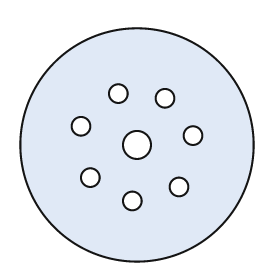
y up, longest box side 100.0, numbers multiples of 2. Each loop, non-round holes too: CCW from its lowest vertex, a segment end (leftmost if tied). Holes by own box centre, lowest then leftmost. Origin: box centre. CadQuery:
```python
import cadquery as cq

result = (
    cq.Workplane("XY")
    .moveTo(0.0, 0.0)
    .circle(50.0)
    .moveTo(-2.0, -24.0)
    .circle(4.0)
    .moveTo(18.0, -18.0)
    .circle(4.0)
    .moveTo(-20.0, -14.0)
    .circle(4.0)
    .moveTo(0.0, 0.0)
    .circle(6.0)
    .moveTo(24.0, 4.0)
    .circle(4.0)
    .moveTo(-24.0, 8.0)
    .circle(4.0)
    .moveTo(12.0, 20.0)
    .circle(4.0)
    .moveTo(-8.0, 22.0)
    .circle(4.0)
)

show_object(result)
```